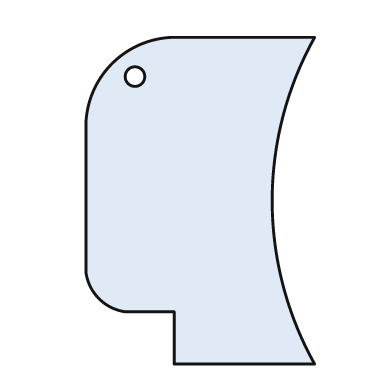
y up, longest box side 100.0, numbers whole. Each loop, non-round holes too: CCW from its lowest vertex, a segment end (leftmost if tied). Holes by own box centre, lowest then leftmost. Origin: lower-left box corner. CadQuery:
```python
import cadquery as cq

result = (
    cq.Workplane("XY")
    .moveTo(27.0, 0.0)
    .lineTo(70.0, 0.0)
    .threePointArc((57.0, 50.0), (70.0, 100.0))
    .lineTo(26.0, 100.0)
    .threePointArc((8.0, 92.0), (0.0, 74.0))
    .lineTo(0.0, 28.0)
    .threePointArc((4.0, 20.0), (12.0, 16.0))
    .lineTo(27.0, 16.0)
    .close()
    .moveTo(15.0, 88.0)
    .circle(3.0)
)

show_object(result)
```